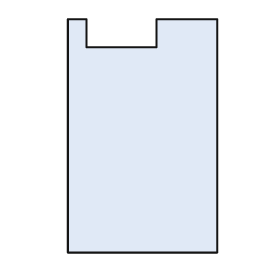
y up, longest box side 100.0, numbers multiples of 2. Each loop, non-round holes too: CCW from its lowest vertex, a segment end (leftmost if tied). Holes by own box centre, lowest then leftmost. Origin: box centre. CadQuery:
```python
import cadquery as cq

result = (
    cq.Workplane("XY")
    .moveTo(-32.0, -50.0)
    .lineTo(32.0, -50.0)
    .lineTo(32.0, 50.0)
    .lineTo(6.0, 50.0)
    .lineTo(6.0, 38.0)
    .lineTo(-24.0, 38.0)
    .lineTo(-24.0, 50.0)
    .lineTo(-32.0, 50.0)
    .close()
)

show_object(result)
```